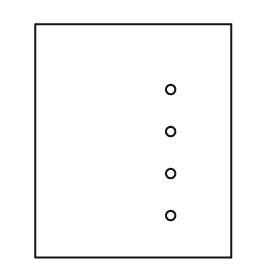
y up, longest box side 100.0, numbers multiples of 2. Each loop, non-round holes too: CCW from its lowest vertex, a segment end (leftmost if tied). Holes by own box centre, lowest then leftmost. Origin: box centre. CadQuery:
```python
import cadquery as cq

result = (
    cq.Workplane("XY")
    .moveTo(-42.0, -50.0)
    .lineTo(42.0, -50.0)
    .lineTo(42.0, 50.0)
    .lineTo(-42.0, 50.0)
    .close()
    .moveTo(16.0, -32.0)
    .circle(2.0)
    .moveTo(16.0, -14.0)
    .circle(2.0)
    .moveTo(16.0, 4.0)
    .circle(2.0)
    .moveTo(16.0, 22.0)
    .circle(2.0)
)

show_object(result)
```